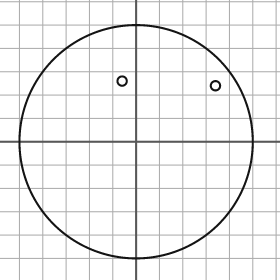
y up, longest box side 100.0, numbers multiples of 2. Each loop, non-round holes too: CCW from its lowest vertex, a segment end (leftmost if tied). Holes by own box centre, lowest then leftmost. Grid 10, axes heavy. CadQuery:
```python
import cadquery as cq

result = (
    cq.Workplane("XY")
    .moveTo(0.0, 0.0)
    .circle(50.0)
    .moveTo(34.0, 24.0)
    .circle(2.0)
    .moveTo(-6.0, 26.0)
    .circle(2.0)
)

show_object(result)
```